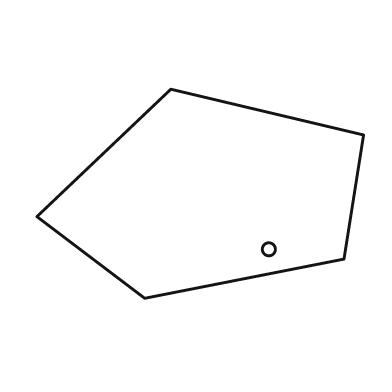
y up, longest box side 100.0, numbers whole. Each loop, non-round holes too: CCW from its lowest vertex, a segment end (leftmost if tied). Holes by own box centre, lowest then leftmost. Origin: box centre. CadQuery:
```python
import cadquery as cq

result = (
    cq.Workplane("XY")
    .moveTo(-17.0, -32.0)
    .lineTo(44.0, -20.0)
    .lineTo(50.0, 18.0)
    .lineTo(-9.0, 32.0)
    .lineTo(-50.0, -7.0)
    .close()
    .moveTo(21.0, -17.0)
    .circle(2.0)
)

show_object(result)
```